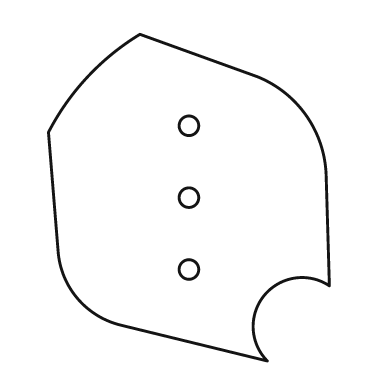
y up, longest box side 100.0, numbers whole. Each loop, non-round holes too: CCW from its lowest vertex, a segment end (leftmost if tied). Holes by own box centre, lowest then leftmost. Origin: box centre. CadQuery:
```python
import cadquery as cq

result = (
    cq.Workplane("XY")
    .moveTo(24.0, -50.0)
    .threePointArc((23.0, -30.0), (43.0, -27.0))
    .lineTo(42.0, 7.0)
    .threePointArc((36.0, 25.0), (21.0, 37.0))
    .lineTo(-15.0, 50.0)
    .threePointArc((-31.0, 37.0), (-43.0, 20.0))
    .lineTo(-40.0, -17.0)
    .threePointArc((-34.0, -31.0), (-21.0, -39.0))
    .close()
    .moveTo(0.0, -22.0)
    .circle(3.0)
    .moveTo(0.0, 0.0)
    .circle(3.0)
    .moveTo(0.0, 22.0)
    .circle(3.0)
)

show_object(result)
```